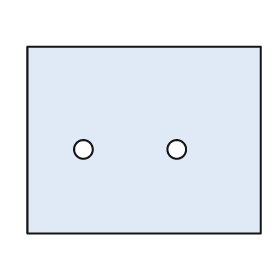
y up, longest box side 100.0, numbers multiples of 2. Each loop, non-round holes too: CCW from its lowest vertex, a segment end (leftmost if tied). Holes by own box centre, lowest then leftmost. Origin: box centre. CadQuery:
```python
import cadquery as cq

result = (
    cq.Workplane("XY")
    .moveTo(-50.0, -40.0)
    .lineTo(50.0, -40.0)
    .lineTo(50.0, 40.0)
    .lineTo(-50.0, 40.0)
    .close()
    .moveTo(-26.0, -4.0)
    .circle(4.0)
    .moveTo(14.0, -4.0)
    .circle(4.0)
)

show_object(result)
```